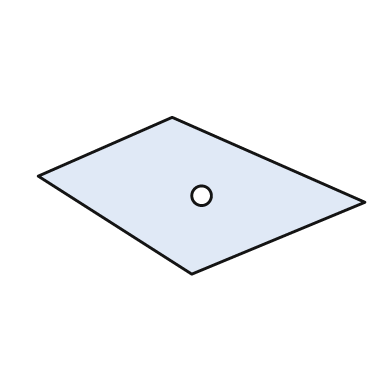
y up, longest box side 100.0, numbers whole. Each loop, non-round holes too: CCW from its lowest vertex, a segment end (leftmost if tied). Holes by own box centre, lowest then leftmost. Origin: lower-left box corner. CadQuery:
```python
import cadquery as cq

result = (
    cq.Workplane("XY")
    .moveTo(47.0, 0.0)
    .lineTo(100.0, 22.0)
    .lineTo(41.0, 48.0)
    .lineTo(0.0, 30.0)
    .close()
    .moveTo(50.0, 24.0)
    .circle(3.0)
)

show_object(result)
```